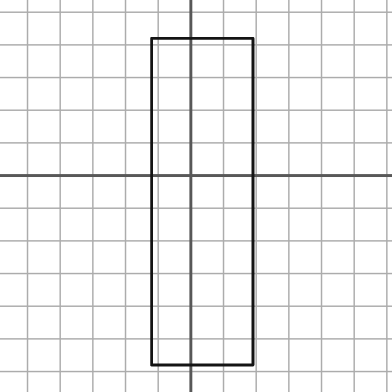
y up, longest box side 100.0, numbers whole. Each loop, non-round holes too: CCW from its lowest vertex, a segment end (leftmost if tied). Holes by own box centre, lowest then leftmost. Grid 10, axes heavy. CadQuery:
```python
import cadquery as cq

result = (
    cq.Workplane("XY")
    .moveTo(-12.0, -58.0)
    .lineTo(19.0, -58.0)
    .lineTo(19.0, 42.0)
    .lineTo(-12.0, 42.0)
    .close()
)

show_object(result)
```